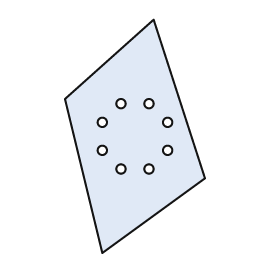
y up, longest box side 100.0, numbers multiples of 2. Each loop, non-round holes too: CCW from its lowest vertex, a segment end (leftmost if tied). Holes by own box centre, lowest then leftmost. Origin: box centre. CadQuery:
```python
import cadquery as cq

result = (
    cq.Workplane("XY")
    .moveTo(-14.0, -50.0)
    .lineTo(30.0, -18.0)
    .lineTo(8.0, 50.0)
    .lineTo(-30.0, 16.0)
    .close()
    .moveTo(-6.0, -14.0)
    .circle(2.0)
    .moveTo(6.0, -14.0)
    .circle(2.0)
    .moveTo(-14.0, -6.0)
    .circle(2.0)
    .moveTo(14.0, -6.0)
    .circle(2.0)
    .moveTo(-14.0, 6.0)
    .circle(2.0)
    .moveTo(14.0, 6.0)
    .circle(2.0)
    .moveTo(-6.0, 14.0)
    .circle(2.0)
    .moveTo(6.0, 14.0)
    .circle(2.0)
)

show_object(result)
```